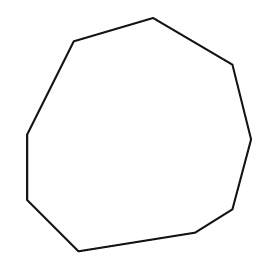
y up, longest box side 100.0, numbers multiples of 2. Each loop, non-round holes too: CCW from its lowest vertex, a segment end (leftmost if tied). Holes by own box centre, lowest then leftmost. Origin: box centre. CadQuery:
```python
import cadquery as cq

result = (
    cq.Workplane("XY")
    .moveTo(-26.0, -50.0)
    .lineTo(24.0, -42.0)
    .lineTo(40.0, -32.0)
    .lineTo(48.0, -2.0)
    .lineTo(40.0, 30.0)
    .lineTo(6.0, 50.0)
    .lineTo(-28.0, 40.0)
    .lineTo(-48.0, 0.0)
    .lineTo(-48.0, -28.0)
    .close()
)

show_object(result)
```